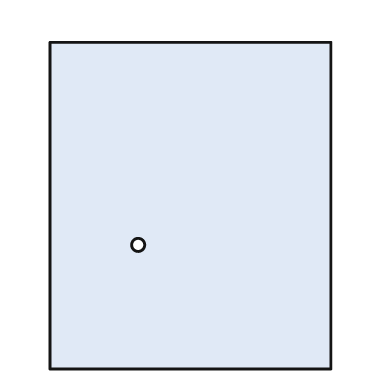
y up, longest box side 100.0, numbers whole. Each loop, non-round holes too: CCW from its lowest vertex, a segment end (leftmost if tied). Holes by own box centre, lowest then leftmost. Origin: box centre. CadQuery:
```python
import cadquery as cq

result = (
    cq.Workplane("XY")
    .moveTo(-43.0, -50.0)
    .lineTo(43.0, -50.0)
    .lineTo(43.0, 50.0)
    .lineTo(-43.0, 50.0)
    .close()
    .moveTo(-16.0, -12.0)
    .circle(2.0)
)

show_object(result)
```